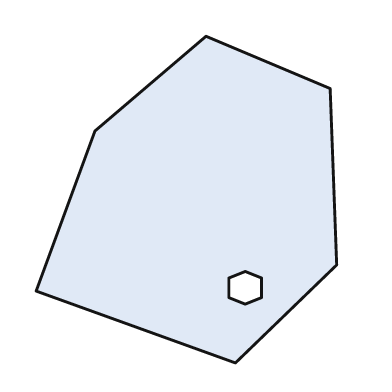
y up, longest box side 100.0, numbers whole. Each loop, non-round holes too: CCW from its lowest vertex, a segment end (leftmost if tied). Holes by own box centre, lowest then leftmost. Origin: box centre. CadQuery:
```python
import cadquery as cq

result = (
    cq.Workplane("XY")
    .moveTo(15.0, -50.0)
    .lineTo(46.0, -20.0)
    .lineTo(44.0, 34.0)
    .lineTo(6.0, 50.0)
    .lineTo(-28.0, 21.0)
    .lineTo(-46.0, -28.0)
    .close()
    .moveTo(18.0, -32.0)
    .lineTo(23.0, -30.0)
    .lineTo(23.0, -24.0)
    .lineTo(18.0, -22.0)
    .lineTo(13.0, -24.0)
    .lineTo(13.0, -30.0)
    .close()
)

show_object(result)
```